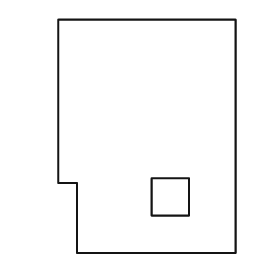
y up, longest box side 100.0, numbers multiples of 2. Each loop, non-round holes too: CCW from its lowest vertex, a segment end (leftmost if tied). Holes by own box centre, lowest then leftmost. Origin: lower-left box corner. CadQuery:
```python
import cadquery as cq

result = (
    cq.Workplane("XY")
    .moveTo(8.0, 0.0)
    .lineTo(76.0, 0.0)
    .lineTo(76.0, 100.0)
    .lineTo(0.0, 100.0)
    .lineTo(0.0, 30.0)
    .lineTo(8.0, 30.0)
    .close()
    .moveTo(40.0, 16.0)
    .lineTo(56.0, 16.0)
    .lineTo(56.0, 32.0)
    .lineTo(40.0, 32.0)
    .close()
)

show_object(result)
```